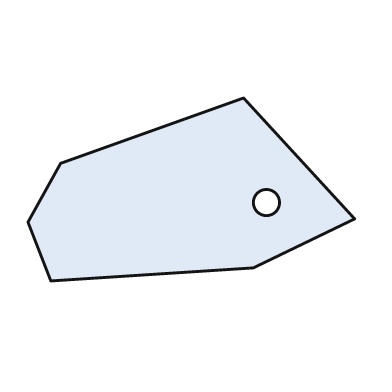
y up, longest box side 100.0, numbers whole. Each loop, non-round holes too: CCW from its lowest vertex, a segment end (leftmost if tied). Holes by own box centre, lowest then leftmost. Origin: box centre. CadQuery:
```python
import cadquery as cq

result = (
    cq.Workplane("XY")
    .moveTo(-43.0, -28.0)
    .lineTo(19.0, -24.0)
    .lineTo(50.0, -9.0)
    .lineTo(16.0, 28.0)
    .lineTo(-40.0, 8.0)
    .lineTo(-50.0, -10.0)
    .close()
    .moveTo(23.0, -4.0)
    .circle(4.0)
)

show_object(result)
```